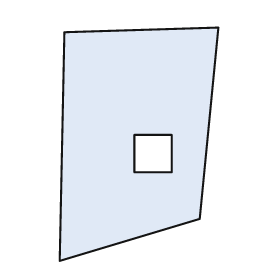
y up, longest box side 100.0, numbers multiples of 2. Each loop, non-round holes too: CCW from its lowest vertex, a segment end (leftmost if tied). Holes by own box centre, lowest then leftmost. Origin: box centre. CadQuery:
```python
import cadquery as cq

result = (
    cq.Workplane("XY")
    .moveTo(-34.0, -50.0)
    .lineTo(26.0, -32.0)
    .lineTo(34.0, 50.0)
    .lineTo(-32.0, 48.0)
    .close()
    .moveTo(-2.0, -12.0)
    .lineTo(14.0, -12.0)
    .lineTo(14.0, 4.0)
    .lineTo(-2.0, 4.0)
    .close()
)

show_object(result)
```